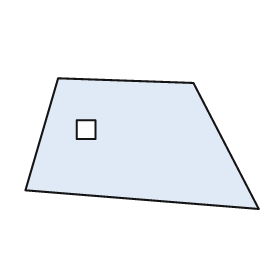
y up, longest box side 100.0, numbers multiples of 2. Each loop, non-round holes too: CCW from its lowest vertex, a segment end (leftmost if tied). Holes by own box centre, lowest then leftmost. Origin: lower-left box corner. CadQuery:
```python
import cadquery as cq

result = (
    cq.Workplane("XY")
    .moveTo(100.0, 0.0)
    .lineTo(72.0, 54.0)
    .lineTo(14.0, 56.0)
    .lineTo(0.0, 8.0)
    .close()
    .moveTo(22.0, 30.0)
    .lineTo(30.0, 30.0)
    .lineTo(30.0, 38.0)
    .lineTo(22.0, 38.0)
    .close()
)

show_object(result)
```